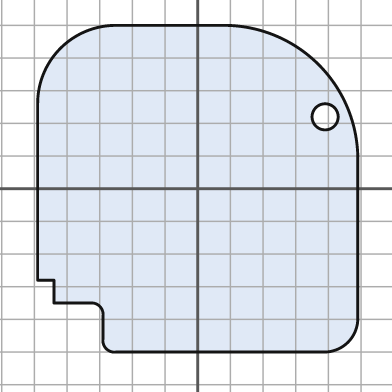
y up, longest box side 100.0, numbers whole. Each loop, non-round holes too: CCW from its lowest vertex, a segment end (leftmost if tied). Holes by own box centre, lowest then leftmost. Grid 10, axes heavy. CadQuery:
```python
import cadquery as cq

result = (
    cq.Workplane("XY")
    .moveTo(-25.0, -50.0)
    .lineTo(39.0, -50.0)
    .threePointArc((46.0, -47.0), (49.0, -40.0))
    .lineTo(49.0, 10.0)
    .threePointArc((37.0, 38.0), (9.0, 50.0))
    .lineTo(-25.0, 50.0)
    .threePointArc((-42.0, 43.0), (-49.0, 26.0))
    .lineTo(-49.0, -28.0)
    .lineTo(-44.0, -28.0)
    .lineTo(-44.0, -35.0)
    .lineTo(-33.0, -35.0)
    .threePointArc((-30.0, -36.0), (-29.0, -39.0))
    .lineTo(-29.0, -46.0)
    .threePointArc((-28.0, -49.0), (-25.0, -50.0))
    .close()
    .moveTo(39.0, 22.0)
    .circle(4.0)
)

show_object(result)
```